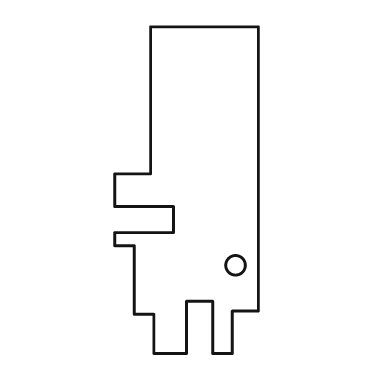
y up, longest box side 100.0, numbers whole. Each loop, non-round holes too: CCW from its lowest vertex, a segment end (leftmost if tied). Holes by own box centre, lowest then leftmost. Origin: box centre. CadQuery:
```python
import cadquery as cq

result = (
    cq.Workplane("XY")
    .moveTo(-10.0, -50.0)
    .lineTo(0.0, -50.0)
    .lineTo(0.0, -34.0)
    .lineTo(8.0, -34.0)
    .lineTo(8.0, -50.0)
    .lineTo(14.0, -50.0)
    .lineTo(14.0, -37.0)
    .lineTo(22.0, -37.0)
    .lineTo(22.0, 50.0)
    .lineTo(-11.0, 50.0)
    .lineTo(-11.0, 5.0)
    .lineTo(-22.0, 5.0)
    .lineTo(-22.0, -5.0)
    .lineTo(-4.0, -5.0)
    .lineTo(-4.0, -13.0)
    .lineTo(-22.0, -13.0)
    .lineTo(-22.0, -17.0)
    .lineTo(-16.0, -17.0)
    .lineTo(-16.0, -38.0)
    .lineTo(-10.0, -38.0)
    .close()
    .moveTo(15.0, -23.0)
    .circle(3.0)
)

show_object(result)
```